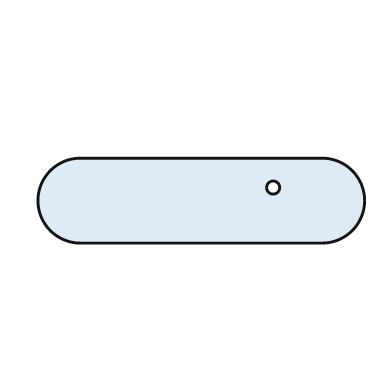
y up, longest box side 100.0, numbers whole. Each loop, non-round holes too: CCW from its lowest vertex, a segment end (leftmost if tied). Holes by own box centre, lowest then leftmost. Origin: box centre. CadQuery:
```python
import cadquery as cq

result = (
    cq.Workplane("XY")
    .moveTo(-37.0, -13.0)
    .lineTo(37.0, -13.0)
    .threePointArc((50.0, 0.0), (37.0, 13.0))
    .lineTo(-37.0, 13.0)
    .threePointArc((-50.0, 0.0), (-37.0, -13.0))
    .close()
    .moveTo(22.0, 4.0)
    .circle(2.0)
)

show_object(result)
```